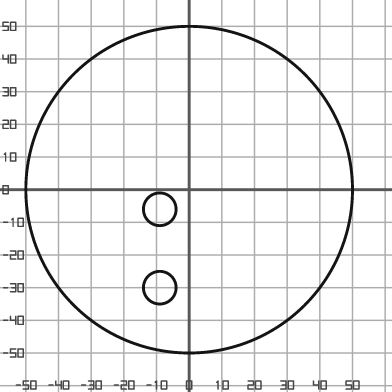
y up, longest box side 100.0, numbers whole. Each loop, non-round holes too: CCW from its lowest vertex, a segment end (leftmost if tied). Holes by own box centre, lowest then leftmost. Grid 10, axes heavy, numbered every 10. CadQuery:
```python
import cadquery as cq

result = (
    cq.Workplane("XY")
    .moveTo(0.0, 0.0)
    .circle(50.0)
    .moveTo(-9.0, -30.0)
    .circle(5.0)
    .moveTo(-9.0, -6.0)
    .circle(5.0)
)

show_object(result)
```